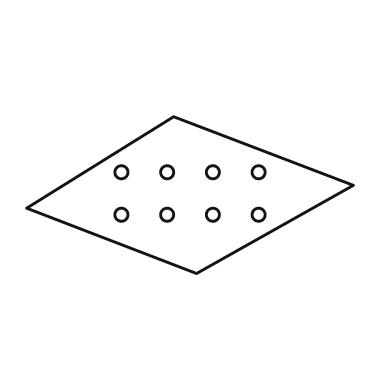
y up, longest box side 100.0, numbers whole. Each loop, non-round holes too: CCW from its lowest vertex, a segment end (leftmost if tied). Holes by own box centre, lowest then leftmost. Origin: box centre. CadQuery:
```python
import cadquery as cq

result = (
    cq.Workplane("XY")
    .moveTo(2.0, -24.0)
    .lineTo(50.0, 3.0)
    .lineTo(-5.0, 24.0)
    .lineTo(-50.0, -4.0)
    .close()
    .moveTo(-21.0, -6.0)
    .circle(2.0)
    .moveTo(-7.0, -6.0)
    .circle(2.0)
    .moveTo(7.0, -6.0)
    .circle(2.0)
    .moveTo(21.0, -6.0)
    .circle(2.0)
    .moveTo(-21.0, 7.0)
    .circle(2.0)
    .moveTo(-7.0, 7.0)
    .circle(2.0)
    .moveTo(7.0, 7.0)
    .circle(2.0)
    .moveTo(21.0, 7.0)
    .circle(2.0)
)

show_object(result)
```